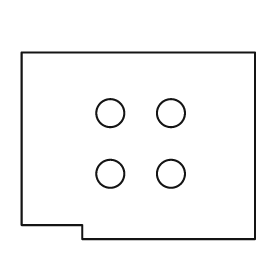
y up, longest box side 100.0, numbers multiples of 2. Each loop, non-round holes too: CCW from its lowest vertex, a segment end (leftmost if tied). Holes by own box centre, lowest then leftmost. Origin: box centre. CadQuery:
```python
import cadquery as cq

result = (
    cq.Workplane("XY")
    .moveTo(-24.0, -40.0)
    .lineTo(50.0, -40.0)
    .lineTo(50.0, 40.0)
    .lineTo(-50.0, 40.0)
    .lineTo(-50.0, -34.0)
    .lineTo(-24.0, -34.0)
    .close()
    .moveTo(-12.0, -12.0)
    .circle(6.0)
    .moveTo(14.0, -12.0)
    .circle(6.0)
    .moveTo(-12.0, 14.0)
    .circle(6.0)
    .moveTo(14.0, 14.0)
    .circle(6.0)
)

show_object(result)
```